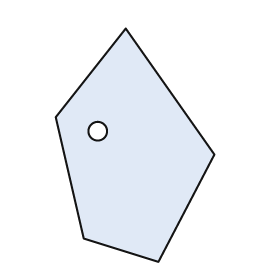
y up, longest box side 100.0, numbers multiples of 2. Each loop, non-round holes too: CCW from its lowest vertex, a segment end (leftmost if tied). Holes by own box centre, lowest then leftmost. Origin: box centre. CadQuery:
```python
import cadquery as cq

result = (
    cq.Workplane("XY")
    .moveTo(10.0, -50.0)
    .lineTo(34.0, -4.0)
    .lineTo(-4.0, 50.0)
    .lineTo(-34.0, 12.0)
    .lineTo(-22.0, -40.0)
    .close()
    .moveTo(-16.0, 6.0)
    .circle(4.0)
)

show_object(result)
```